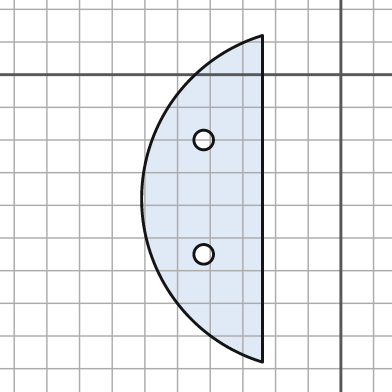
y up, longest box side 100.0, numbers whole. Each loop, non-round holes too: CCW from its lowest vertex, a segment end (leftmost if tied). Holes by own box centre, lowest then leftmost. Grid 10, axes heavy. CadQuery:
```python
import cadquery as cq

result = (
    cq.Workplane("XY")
    .moveTo(-24.0, -88.0)
    .lineTo(-24.0, 12.0)
    .threePointArc((-61.0, -38.0), (-24.0, -88.0))
    .close()
    .moveTo(-42.0, -55.0)
    .circle(3.0)
    .moveTo(-42.0, -20.0)
    .circle(3.0)
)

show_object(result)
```